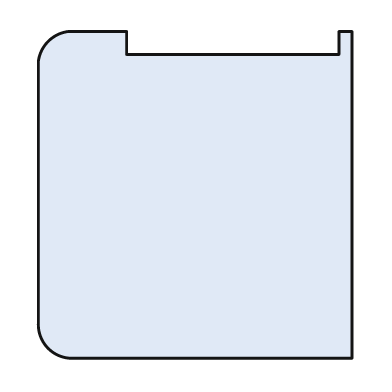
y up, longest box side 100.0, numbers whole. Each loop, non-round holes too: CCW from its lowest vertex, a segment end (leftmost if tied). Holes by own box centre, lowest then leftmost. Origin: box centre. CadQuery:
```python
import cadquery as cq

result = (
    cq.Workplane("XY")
    .moveTo(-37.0, -50.0)
    .lineTo(48.0, -50.0)
    .lineTo(48.0, 50.0)
    .lineTo(44.0, 50.0)
    .lineTo(44.0, 43.0)
    .lineTo(-21.0, 43.0)
    .lineTo(-21.0, 50.0)
    .lineTo(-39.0, 50.0)
    .threePointArc((-45.0, 47.0), (-48.0, 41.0))
    .lineTo(-48.0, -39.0)
    .threePointArc((-45.0, -47.0), (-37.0, -50.0))
    .close()
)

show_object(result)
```